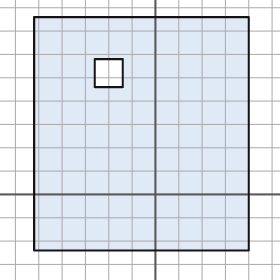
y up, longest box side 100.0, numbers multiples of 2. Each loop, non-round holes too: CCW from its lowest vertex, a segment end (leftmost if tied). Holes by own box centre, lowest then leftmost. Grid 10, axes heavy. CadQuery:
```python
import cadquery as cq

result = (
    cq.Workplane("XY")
    .moveTo(-52.0, -24.0)
    .lineTo(40.0, -24.0)
    .lineTo(40.0, 76.0)
    .lineTo(-52.0, 76.0)
    .close()
    .moveTo(-26.0, 46.0)
    .lineTo(-14.0, 46.0)
    .lineTo(-14.0, 58.0)
    .lineTo(-26.0, 58.0)
    .close()
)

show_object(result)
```